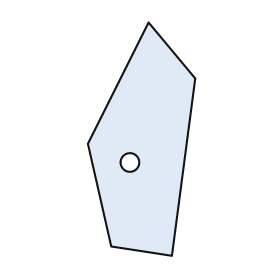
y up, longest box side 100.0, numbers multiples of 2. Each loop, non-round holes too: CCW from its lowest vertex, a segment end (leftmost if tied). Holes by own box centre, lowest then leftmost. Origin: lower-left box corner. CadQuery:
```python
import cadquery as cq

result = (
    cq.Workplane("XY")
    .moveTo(36.0, 0.0)
    .lineTo(46.0, 76.0)
    .lineTo(26.0, 100.0)
    .lineTo(0.0, 48.0)
    .lineTo(10.0, 4.0)
    .close()
    .moveTo(18.0, 40.0)
    .circle(4.0)
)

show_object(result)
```